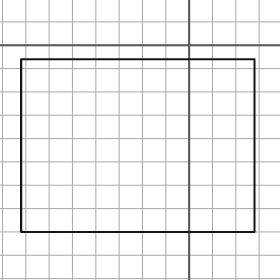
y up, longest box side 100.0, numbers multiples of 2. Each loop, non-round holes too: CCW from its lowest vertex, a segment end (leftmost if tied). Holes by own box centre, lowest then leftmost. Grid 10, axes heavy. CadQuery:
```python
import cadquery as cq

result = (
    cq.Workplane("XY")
    .moveTo(-72.0, -80.0)
    .lineTo(28.0, -80.0)
    .lineTo(28.0, -6.0)
    .lineTo(-72.0, -6.0)
    .close()
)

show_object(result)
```